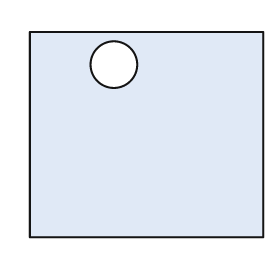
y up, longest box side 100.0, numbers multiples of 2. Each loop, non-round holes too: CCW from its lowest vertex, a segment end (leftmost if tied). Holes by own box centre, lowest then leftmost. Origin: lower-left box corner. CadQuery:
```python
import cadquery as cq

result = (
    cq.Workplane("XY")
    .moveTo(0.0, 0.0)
    .lineTo(100.0, 0.0)
    .lineTo(100.0, 88.0)
    .lineTo(0.0, 88.0)
    .close()
    .moveTo(36.0, 74.0)
    .circle(10.0)
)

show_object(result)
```